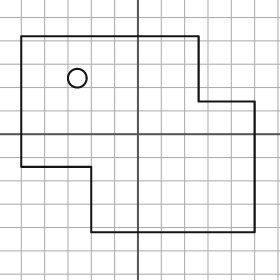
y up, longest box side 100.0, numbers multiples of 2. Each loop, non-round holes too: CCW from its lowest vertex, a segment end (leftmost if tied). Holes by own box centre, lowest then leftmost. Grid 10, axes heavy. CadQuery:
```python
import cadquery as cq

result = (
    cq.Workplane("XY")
    .moveTo(-20.0, -42.0)
    .lineTo(50.0, -42.0)
    .lineTo(50.0, 14.0)
    .lineTo(26.0, 14.0)
    .lineTo(26.0, 42.0)
    .lineTo(-50.0, 42.0)
    .lineTo(-50.0, -14.0)
    .lineTo(-20.0, -14.0)
    .close()
    .moveTo(-26.0, 24.0)
    .circle(4.0)
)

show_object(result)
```